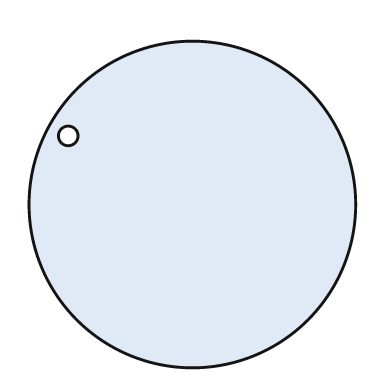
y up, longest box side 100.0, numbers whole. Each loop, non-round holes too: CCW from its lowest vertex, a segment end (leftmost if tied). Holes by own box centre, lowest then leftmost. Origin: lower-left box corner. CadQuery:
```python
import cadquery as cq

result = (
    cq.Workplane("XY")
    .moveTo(50.0, 50.0)
    .circle(50.0)
    .moveTo(12.0, 71.0)
    .circle(3.0)
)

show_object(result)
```